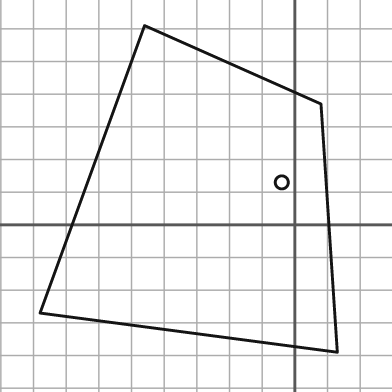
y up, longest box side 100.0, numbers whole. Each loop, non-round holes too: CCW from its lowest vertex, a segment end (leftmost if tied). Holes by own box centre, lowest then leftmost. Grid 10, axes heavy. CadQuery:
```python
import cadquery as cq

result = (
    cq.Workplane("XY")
    .moveTo(13.0, -39.0)
    .lineTo(8.0, 37.0)
    .lineTo(-46.0, 61.0)
    .lineTo(-78.0, -27.0)
    .close()
    .moveTo(-4.0, 13.0)
    .circle(2.0)
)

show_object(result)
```